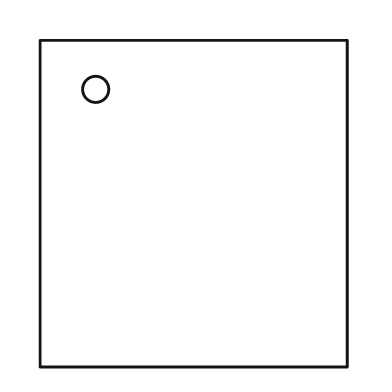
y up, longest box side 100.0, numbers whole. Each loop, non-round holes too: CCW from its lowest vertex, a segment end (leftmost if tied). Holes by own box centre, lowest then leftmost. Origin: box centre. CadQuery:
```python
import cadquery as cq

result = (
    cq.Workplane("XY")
    .moveTo(-47.0, -50.0)
    .lineTo(47.0, -50.0)
    .lineTo(47.0, 50.0)
    .lineTo(-47.0, 50.0)
    .close()
    .moveTo(-30.0, 35.0)
    .circle(4.0)
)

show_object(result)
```